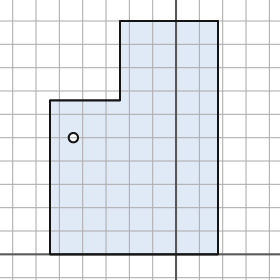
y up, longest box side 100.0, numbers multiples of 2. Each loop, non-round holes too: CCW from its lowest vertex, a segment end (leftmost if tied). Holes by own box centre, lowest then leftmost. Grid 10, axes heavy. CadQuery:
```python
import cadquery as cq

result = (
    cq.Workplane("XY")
    .moveTo(-54.0, 0.0)
    .lineTo(18.0, 0.0)
    .lineTo(18.0, 100.0)
    .lineTo(-24.0, 100.0)
    .lineTo(-24.0, 66.0)
    .lineTo(-54.0, 66.0)
    .close()
    .moveTo(-44.0, 50.0)
    .circle(2.0)
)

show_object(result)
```